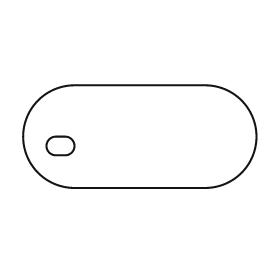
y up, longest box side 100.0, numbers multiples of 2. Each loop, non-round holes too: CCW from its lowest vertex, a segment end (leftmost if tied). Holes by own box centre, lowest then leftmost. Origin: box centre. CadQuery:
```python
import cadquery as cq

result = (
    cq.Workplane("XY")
    .moveTo(-28.0, -22.0)
    .lineTo(28.0, -22.0)
    .threePointArc((50.0, 0.0), (28.0, 22.0))
    .lineTo(-28.0, 22.0)
    .threePointArc((-50.0, 0.0), (-28.0, -22.0))
    .close()
    .moveTo(-36.0, -8.0)
    .lineTo(-32.0, -8.0)
    .threePointArc((-28.0, -4.0), (-32.0, 0.0))
    .lineTo(-36.0, 0.0)
    .threePointArc((-40.0, -4.0), (-36.0, -8.0))
    .close()
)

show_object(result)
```